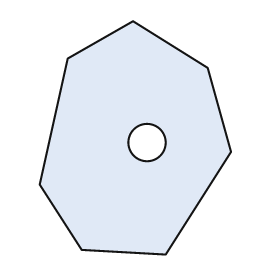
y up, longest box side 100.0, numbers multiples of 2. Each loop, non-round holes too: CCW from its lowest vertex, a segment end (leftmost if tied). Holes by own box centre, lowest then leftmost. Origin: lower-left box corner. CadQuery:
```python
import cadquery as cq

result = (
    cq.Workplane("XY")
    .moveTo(54.0, 0.0)
    .lineTo(82.0, 44.0)
    .lineTo(72.0, 80.0)
    .lineTo(40.0, 100.0)
    .lineTo(12.0, 84.0)
    .lineTo(0.0, 30.0)
    .lineTo(18.0, 2.0)
    .close()
    .moveTo(46.0, 48.0)
    .circle(8.0)
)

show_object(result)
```